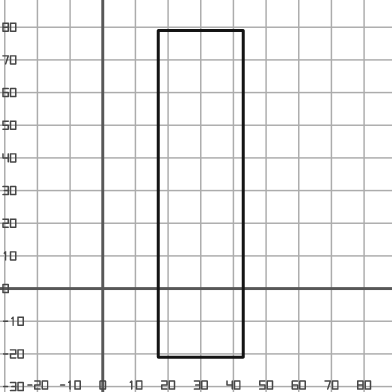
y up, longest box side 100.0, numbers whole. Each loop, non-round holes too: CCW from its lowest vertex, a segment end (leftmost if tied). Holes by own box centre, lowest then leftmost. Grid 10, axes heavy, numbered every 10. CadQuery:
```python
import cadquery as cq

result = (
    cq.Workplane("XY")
    .moveTo(17.0, -21.0)
    .lineTo(43.0, -21.0)
    .lineTo(43.0, 79.0)
    .lineTo(17.0, 79.0)
    .close()
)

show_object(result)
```